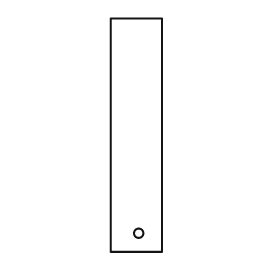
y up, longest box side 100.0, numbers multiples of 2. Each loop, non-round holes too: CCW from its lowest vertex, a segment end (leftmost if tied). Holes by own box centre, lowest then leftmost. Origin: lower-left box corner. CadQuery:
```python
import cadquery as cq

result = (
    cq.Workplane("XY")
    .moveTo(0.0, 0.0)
    .lineTo(22.0, 0.0)
    .lineTo(22.0, 100.0)
    .lineTo(0.0, 100.0)
    .close()
    .moveTo(12.0, 8.0)
    .circle(2.0)
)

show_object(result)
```